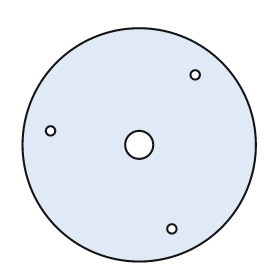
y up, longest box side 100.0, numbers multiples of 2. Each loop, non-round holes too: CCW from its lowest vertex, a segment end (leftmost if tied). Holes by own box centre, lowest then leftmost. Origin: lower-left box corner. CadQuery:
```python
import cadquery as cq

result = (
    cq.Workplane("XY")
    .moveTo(50.0, 50.0)
    .circle(50.0)
    .moveTo(64.0, 14.0)
    .circle(2.0)
    .moveTo(50.0, 50.0)
    .circle(6.0)
    .moveTo(12.0, 56.0)
    .circle(2.0)
    .moveTo(74.0, 80.0)
    .circle(2.0)
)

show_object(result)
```